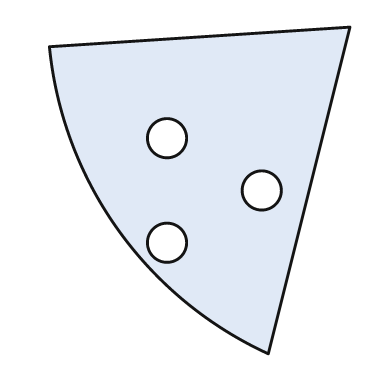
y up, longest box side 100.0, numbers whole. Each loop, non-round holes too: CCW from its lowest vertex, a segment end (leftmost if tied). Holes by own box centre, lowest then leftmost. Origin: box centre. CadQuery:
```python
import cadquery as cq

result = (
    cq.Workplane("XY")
    .moveTo(21.0, -50.0)
    .lineTo(46.0, 50.0)
    .lineTo(-46.0, 44.0)
    .threePointArc((-25.0, -12.0), (21.0, -50.0))
    .close()
    .moveTo(-10.0, -16.0)
    .circle(6.0)
    .moveTo(19.0, 0.0)
    .circle(6.0)
    .moveTo(-10.0, 16.0)
    .circle(6.0)
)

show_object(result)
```